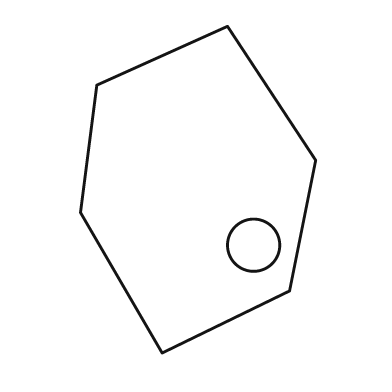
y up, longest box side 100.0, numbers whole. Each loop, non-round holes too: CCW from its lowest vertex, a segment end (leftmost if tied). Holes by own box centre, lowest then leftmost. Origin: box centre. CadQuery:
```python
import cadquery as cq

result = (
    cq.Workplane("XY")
    .moveTo(-11.0, -50.0)
    .lineTo(28.0, -31.0)
    .lineTo(36.0, 9.0)
    .lineTo(9.0, 50.0)
    .lineTo(-31.0, 32.0)
    .lineTo(-36.0, -7.0)
    .close()
    .moveTo(17.0, -17.0)
    .circle(8.0)
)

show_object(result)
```